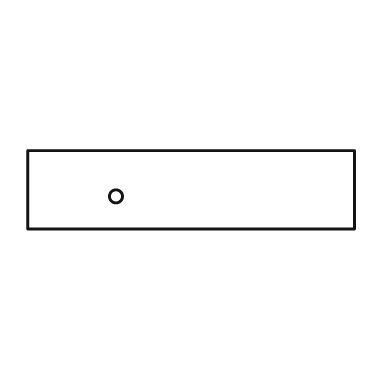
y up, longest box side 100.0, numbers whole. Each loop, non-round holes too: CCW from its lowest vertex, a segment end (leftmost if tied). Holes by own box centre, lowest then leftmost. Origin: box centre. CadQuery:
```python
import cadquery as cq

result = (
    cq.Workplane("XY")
    .moveTo(-50.0, -12.0)
    .lineTo(50.0, -12.0)
    .lineTo(50.0, 12.0)
    .lineTo(-50.0, 12.0)
    .close()
    .moveTo(-23.0, -2.0)
    .circle(2.0)
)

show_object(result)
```